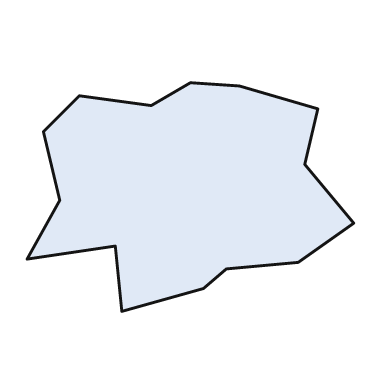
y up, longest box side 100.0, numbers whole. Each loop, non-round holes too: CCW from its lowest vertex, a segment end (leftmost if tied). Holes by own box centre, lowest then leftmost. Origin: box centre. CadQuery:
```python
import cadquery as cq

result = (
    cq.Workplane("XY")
    .moveTo(-21.0, -35.0)
    .lineTo(4.0, -28.0)
    .lineTo(11.0, -22.0)
    .lineTo(33.0, -20.0)
    .lineTo(50.0, -8.0)
    .lineTo(35.0, 10.0)
    .lineTo(39.0, 27.0)
    .lineTo(15.0, 34.0)
    .lineTo(0.0, 35.0)
    .lineTo(-12.0, 28.0)
    .lineTo(-34.0, 31.0)
    .lineTo(-45.0, 20.0)
    .lineTo(-40.0, -1.0)
    .lineTo(-50.0, -19.0)
    .lineTo(-23.0, -15.0)
    .close()
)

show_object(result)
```